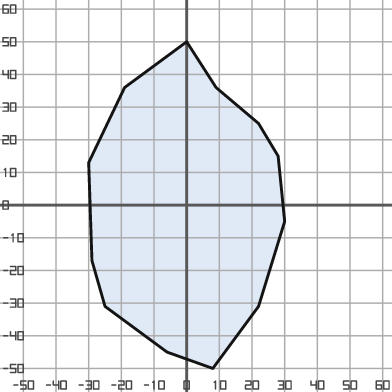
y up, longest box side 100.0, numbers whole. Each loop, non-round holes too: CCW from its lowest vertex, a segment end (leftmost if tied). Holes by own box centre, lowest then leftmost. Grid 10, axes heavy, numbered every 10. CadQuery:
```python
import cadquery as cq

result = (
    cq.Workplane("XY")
    .moveTo(8.0, -50.0)
    .lineTo(22.0, -31.0)
    .lineTo(30.0, -5.0)
    .lineTo(28.0, 15.0)
    .lineTo(22.0, 25.0)
    .lineTo(9.0, 36.0)
    .lineTo(0.0, 50.0)
    .lineTo(-19.0, 36.0)
    .lineTo(-30.0, 13.0)
    .lineTo(-29.0, -17.0)
    .lineTo(-25.0, -31.0)
    .lineTo(-6.0, -45.0)
    .close()
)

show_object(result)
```